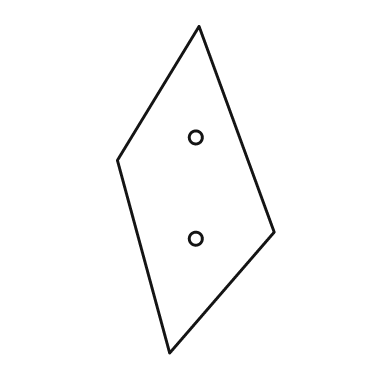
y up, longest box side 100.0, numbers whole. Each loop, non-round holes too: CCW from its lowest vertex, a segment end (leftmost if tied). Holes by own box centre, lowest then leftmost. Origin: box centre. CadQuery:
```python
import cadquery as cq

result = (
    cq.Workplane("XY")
    .moveTo(-8.0, -50.0)
    .lineTo(24.0, -13.0)
    .lineTo(1.0, 50.0)
    .lineTo(-24.0, 9.0)
    .close()
    .moveTo(0.0, -15.0)
    .circle(2.0)
    .moveTo(0.0, 16.0)
    .circle(2.0)
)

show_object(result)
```